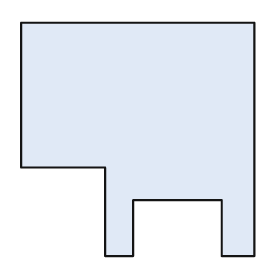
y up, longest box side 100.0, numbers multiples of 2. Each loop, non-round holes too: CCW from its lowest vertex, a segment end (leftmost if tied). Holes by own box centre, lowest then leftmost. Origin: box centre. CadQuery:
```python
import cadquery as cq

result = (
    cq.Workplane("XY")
    .moveTo(-14.0, -50.0)
    .lineTo(-2.0, -50.0)
    .lineTo(-2.0, -26.0)
    .lineTo(36.0, -26.0)
    .lineTo(36.0, -50.0)
    .lineTo(50.0, -50.0)
    .lineTo(50.0, 50.0)
    .lineTo(-50.0, 50.0)
    .lineTo(-50.0, -12.0)
    .lineTo(-14.0, -12.0)
    .close()
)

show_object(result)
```